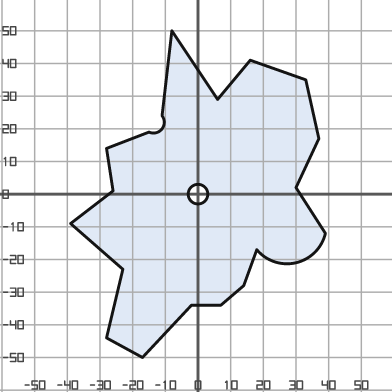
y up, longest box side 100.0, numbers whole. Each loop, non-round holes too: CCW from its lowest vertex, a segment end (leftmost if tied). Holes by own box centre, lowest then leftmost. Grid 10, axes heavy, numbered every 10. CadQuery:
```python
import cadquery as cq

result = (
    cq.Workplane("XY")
    .moveTo(-17.0, -50.0)
    .lineTo(-2.0, -34.0)
    .lineTo(7.0, -34.0)
    .lineTo(14.0, -28.0)
    .lineTo(18.0, -17.0)
    .threePointArc((30.0, -21.0), (39.0, -12.0))
    .lineTo(30.0, 2.0)
    .lineTo(37.0, 17.0)
    .lineTo(33.0, 35.0)
    .lineTo(16.0, 41.0)
    .lineTo(6.0, 29.0)
    .lineTo(-8.0, 50.0)
    .lineTo(-11.0, 24.0)
    .threePointArc((-11.0, 20.0), (-15.0, 19.0))
    .lineTo(-28.0, 14.0)
    .lineTo(-26.0, 1.0)
    .lineTo(-39.0, -9.0)
    .lineTo(-23.0, -23.0)
    .lineTo(-28.0, -44.0)
    .close()
    .moveTo(0.0, 0.0)
    .circle(3.0)
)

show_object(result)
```